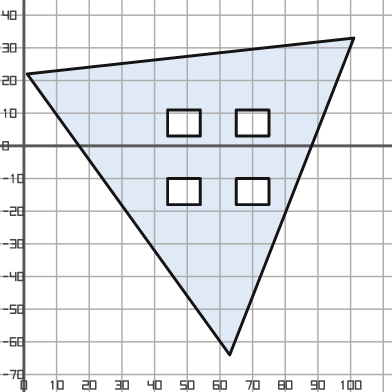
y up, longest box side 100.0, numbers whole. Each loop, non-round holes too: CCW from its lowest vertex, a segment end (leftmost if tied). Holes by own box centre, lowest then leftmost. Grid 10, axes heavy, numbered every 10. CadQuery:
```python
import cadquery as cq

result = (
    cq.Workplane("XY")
    .moveTo(63.0, -64.0)
    .lineTo(101.0, 33.0)
    .lineTo(1.0, 22.0)
    .close()
    .moveTo(44.0, -18.0)
    .lineTo(54.0, -18.0)
    .lineTo(54.0, -10.0)
    .lineTo(44.0, -10.0)
    .close()
    .moveTo(65.0, -18.0)
    .lineTo(75.0, -18.0)
    .lineTo(75.0, -10.0)
    .lineTo(65.0, -10.0)
    .close()
    .moveTo(44.0, 3.0)
    .lineTo(54.0, 3.0)
    .lineTo(54.0, 11.0)
    .lineTo(44.0, 11.0)
    .close()
    .moveTo(65.0, 3.0)
    .lineTo(75.0, 3.0)
    .lineTo(75.0, 11.0)
    .lineTo(65.0, 11.0)
    .close()
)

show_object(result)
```